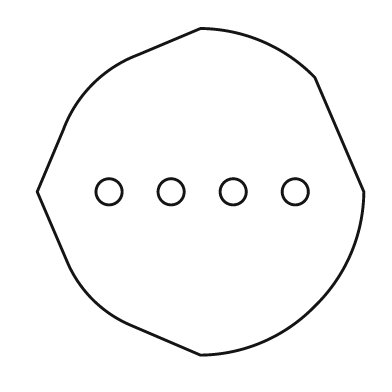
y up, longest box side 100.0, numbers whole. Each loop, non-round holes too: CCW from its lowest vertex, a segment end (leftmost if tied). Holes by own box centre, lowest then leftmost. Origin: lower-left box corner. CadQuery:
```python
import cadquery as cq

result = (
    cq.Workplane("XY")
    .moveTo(50.0, 0.0)
    .threePointArc((69.0, 4.0), (85.0, 15.0))
    .threePointArc((96.0, 31.0), (100.0, 50.0))
    .lineTo(85.0, 85.0)
    .threePointArc((69.0, 96.0), (50.0, 100.0))
    .lineTo(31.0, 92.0)
    .threePointArc((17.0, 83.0), (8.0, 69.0))
    .lineTo(0.0, 50.0)
    .lineTo(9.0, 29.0)
    .threePointArc((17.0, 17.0), (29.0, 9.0))
    .close()
    .moveTo(22.0, 50.0)
    .circle(4.0)
    .moveTo(41.0, 50.0)
    .circle(4.0)
    .moveTo(60.0, 50.0)
    .circle(4.0)
    .moveTo(79.0, 50.0)
    .circle(4.0)
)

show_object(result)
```